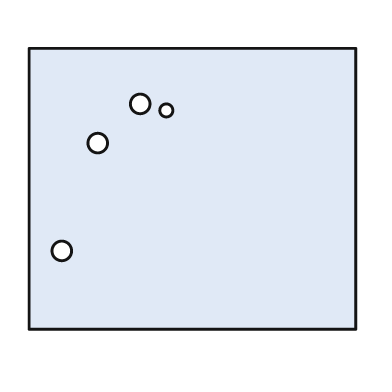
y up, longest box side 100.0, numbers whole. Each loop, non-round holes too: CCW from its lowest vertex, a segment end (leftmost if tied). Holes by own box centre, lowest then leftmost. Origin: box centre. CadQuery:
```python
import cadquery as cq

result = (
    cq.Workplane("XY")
    .moveTo(-50.0, -43.0)
    .lineTo(50.0, -43.0)
    .lineTo(50.0, 43.0)
    .lineTo(-50.0, 43.0)
    .close()
    .moveTo(-40.0, -19.0)
    .circle(3.0)
    .moveTo(-29.0, 14.0)
    .circle(3.0)
    .moveTo(-8.0, 24.0)
    .circle(2.0)
    .moveTo(-16.0, 26.0)
    .circle(3.0)
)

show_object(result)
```